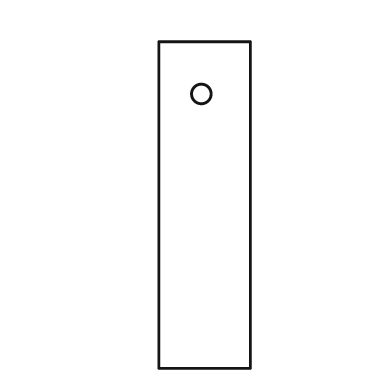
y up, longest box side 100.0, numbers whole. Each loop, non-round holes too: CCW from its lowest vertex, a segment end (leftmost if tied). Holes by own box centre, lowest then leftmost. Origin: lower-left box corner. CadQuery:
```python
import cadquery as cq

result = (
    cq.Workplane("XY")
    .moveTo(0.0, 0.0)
    .lineTo(28.0, 0.0)
    .lineTo(28.0, 100.0)
    .lineTo(0.0, 100.0)
    .close()
    .moveTo(13.0, 84.0)
    .circle(3.0)
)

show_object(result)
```